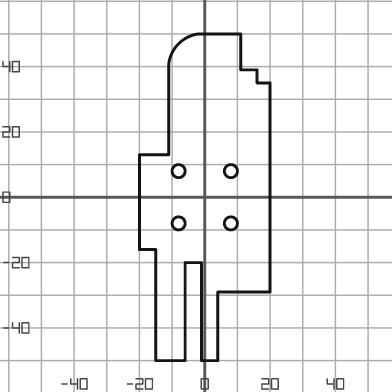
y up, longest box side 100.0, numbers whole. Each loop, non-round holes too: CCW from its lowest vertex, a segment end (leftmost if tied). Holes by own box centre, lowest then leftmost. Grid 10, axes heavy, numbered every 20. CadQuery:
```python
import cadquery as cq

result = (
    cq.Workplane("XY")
    .moveTo(-15.0, -50.0)
    .lineTo(-6.0, -50.0)
    .lineTo(-6.0, -20.0)
    .lineTo(-1.0, -20.0)
    .lineTo(-1.0, -50.0)
    .lineTo(4.0, -50.0)
    .lineTo(4.0, -29.0)
    .lineTo(20.0, -29.0)
    .lineTo(20.0, 35.0)
    .lineTo(16.0, 35.0)
    .lineTo(16.0, 39.0)
    .lineTo(11.0, 39.0)
    .lineTo(11.0, 50.0)
    .lineTo(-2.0, 50.0)
    .threePointArc((-8.0, 47.0), (-11.0, 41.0))
    .lineTo(-11.0, 13.0)
    .lineTo(-20.0, 13.0)
    .lineTo(-20.0, -16.0)
    .lineTo(-15.0, -16.0)
    .close()
    .moveTo(-8.0, -8.0)
    .circle(2.0)
    .moveTo(8.0, -8.0)
    .circle(2.0)
    .moveTo(-8.0, 8.0)
    .circle(2.0)
    .moveTo(8.0, 8.0)
    .circle(2.0)
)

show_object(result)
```